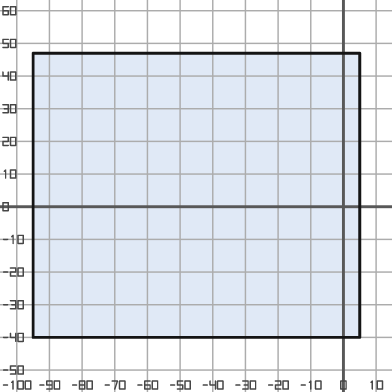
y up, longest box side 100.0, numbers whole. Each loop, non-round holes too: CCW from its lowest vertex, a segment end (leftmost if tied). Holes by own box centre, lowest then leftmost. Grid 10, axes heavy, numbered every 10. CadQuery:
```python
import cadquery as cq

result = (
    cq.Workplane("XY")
    .moveTo(-95.0, -40.0)
    .lineTo(5.0, -40.0)
    .lineTo(5.0, 47.0)
    .lineTo(-95.0, 47.0)
    .close()
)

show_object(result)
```